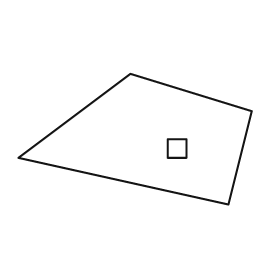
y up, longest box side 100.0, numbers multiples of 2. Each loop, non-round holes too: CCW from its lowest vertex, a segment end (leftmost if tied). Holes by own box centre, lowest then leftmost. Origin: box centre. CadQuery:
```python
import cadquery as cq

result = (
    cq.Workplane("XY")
    .moveTo(40.0, -28.0)
    .lineTo(50.0, 12.0)
    .lineTo(-2.0, 28.0)
    .lineTo(-50.0, -8.0)
    .close()
    .moveTo(14.0, -8.0)
    .lineTo(22.0, -8.0)
    .lineTo(22.0, 0.0)
    .lineTo(14.0, 0.0)
    .close()
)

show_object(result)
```